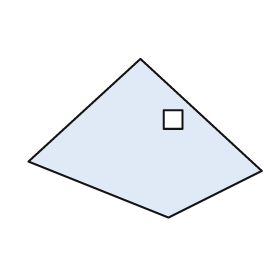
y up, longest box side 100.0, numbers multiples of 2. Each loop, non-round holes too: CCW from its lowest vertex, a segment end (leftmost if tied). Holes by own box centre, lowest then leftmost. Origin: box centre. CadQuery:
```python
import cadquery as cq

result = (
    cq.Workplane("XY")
    .moveTo(10.0, -34.0)
    .lineTo(50.0, -14.0)
    .lineTo(-2.0, 34.0)
    .lineTo(-50.0, -10.0)
    .close()
    .moveTo(8.0, 4.0)
    .lineTo(16.0, 4.0)
    .lineTo(16.0, 12.0)
    .lineTo(8.0, 12.0)
    .close()
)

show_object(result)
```